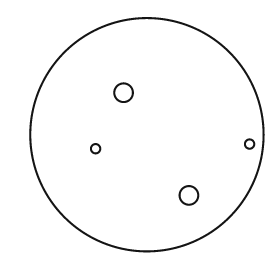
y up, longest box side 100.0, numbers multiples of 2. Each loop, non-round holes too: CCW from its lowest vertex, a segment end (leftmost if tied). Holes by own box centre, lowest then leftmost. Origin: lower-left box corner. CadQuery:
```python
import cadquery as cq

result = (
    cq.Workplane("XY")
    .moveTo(50.0, 50.0)
    .circle(50.0)
    .moveTo(68.0, 24.0)
    .circle(4.0)
    .moveTo(28.0, 44.0)
    .circle(2.0)
    .moveTo(94.0, 46.0)
    .circle(2.0)
    .moveTo(40.0, 68.0)
    .circle(4.0)
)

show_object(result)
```